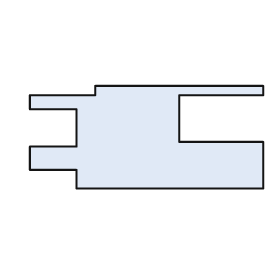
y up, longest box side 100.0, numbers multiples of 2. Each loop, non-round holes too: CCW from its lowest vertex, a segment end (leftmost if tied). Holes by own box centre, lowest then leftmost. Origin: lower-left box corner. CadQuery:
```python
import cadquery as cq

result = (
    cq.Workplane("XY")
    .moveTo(20.0, 0.0)
    .lineTo(100.0, 0.0)
    .lineTo(100.0, 20.0)
    .lineTo(64.0, 20.0)
    .lineTo(64.0, 40.0)
    .lineTo(100.0, 40.0)
    .lineTo(100.0, 44.0)
    .lineTo(28.0, 44.0)
    .lineTo(28.0, 40.0)
    .lineTo(0.0, 40.0)
    .lineTo(0.0, 34.0)
    .lineTo(20.0, 34.0)
    .lineTo(20.0, 18.0)
    .lineTo(0.0, 18.0)
    .lineTo(0.0, 8.0)
    .lineTo(20.0, 8.0)
    .close()
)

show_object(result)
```